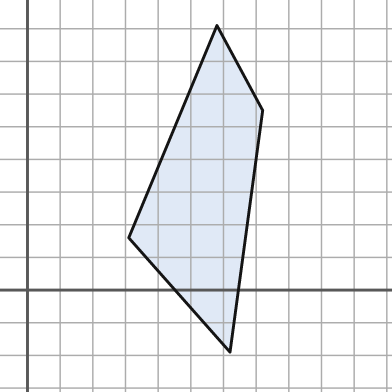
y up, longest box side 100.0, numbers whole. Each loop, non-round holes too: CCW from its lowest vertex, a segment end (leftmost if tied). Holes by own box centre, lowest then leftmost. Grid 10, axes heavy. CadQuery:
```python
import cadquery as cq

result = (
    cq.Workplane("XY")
    .moveTo(62.0, -19.0)
    .lineTo(72.0, 55.0)
    .lineTo(58.0, 81.0)
    .lineTo(31.0, 16.0)
    .close()
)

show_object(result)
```